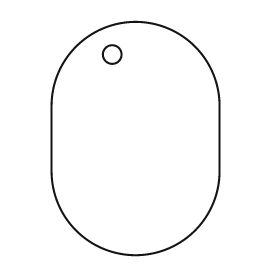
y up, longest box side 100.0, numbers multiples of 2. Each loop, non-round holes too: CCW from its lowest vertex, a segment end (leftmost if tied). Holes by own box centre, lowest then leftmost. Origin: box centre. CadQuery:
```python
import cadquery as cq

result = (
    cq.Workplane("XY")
    .moveTo(-36.0, -14.0)
    .threePointArc((0.0, -50.0), (36.0, -14.0))
    .lineTo(36.0, 14.0)
    .threePointArc((0.0, 50.0), (-36.0, 14.0))
    .close()
    .moveTo(-10.0, 36.0)
    .circle(4.0)
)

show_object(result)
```